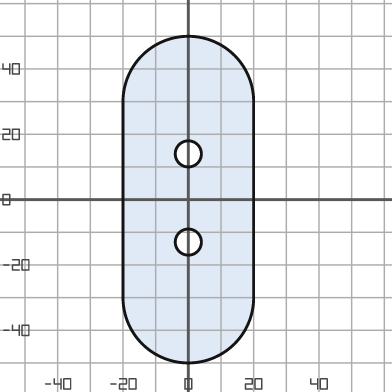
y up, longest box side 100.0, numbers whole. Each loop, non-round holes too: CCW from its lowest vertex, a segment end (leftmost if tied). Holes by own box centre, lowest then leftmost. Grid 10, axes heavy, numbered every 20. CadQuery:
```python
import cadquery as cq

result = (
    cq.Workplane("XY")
    .moveTo(-20.0, -30.0)
    .threePointArc((0.0, -50.0), (20.0, -30.0))
    .lineTo(20.0, 30.0)
    .threePointArc((0.0, 50.0), (-20.0, 30.0))
    .close()
    .moveTo(0.0, -13.0)
    .circle(4.0)
    .moveTo(0.0, 14.0)
    .circle(4.0)
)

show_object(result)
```